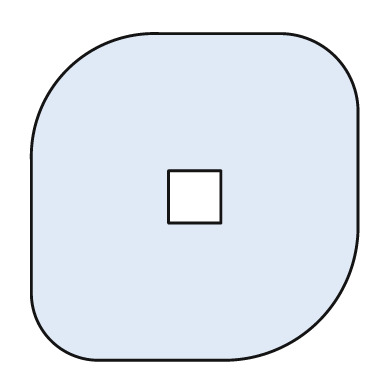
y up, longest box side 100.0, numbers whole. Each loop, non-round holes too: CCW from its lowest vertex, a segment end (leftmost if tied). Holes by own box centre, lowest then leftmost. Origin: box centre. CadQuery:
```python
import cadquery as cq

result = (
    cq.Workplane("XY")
    .moveTo(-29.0, -50.0)
    .lineTo(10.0, -50.0)
    .threePointArc((38.0, -38.0), (50.0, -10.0))
    .lineTo(50.0, 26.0)
    .threePointArc((43.0, 43.0), (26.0, 50.0))
    .lineTo(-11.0, 50.0)
    .threePointArc((-39.0, 39.0), (-50.0, 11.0))
    .lineTo(-50.0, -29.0)
    .threePointArc((-44.0, -44.0), (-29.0, -50.0))
    .close()
    .moveTo(-8.0, -8.0)
    .lineTo(8.0, -8.0)
    .lineTo(8.0, 8.0)
    .lineTo(-8.0, 8.0)
    .close()
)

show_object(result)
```